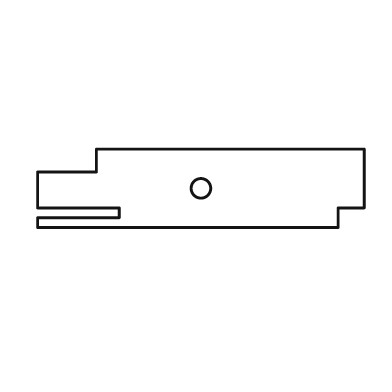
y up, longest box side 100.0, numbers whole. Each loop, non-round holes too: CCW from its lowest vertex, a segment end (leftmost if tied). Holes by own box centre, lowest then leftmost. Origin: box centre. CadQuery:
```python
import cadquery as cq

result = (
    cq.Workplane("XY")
    .moveTo(-50.0, -12.0)
    .lineTo(42.0, -12.0)
    .lineTo(42.0, -6.0)
    .lineTo(50.0, -6.0)
    .lineTo(50.0, 12.0)
    .lineTo(-32.0, 12.0)
    .lineTo(-32.0, 5.0)
    .lineTo(-50.0, 5.0)
    .lineTo(-50.0, -6.0)
    .lineTo(-25.0, -6.0)
    .lineTo(-25.0, -9.0)
    .lineTo(-50.0, -9.0)
    .close()
    .moveTo(0.0, 0.0)
    .circle(3.0)
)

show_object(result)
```